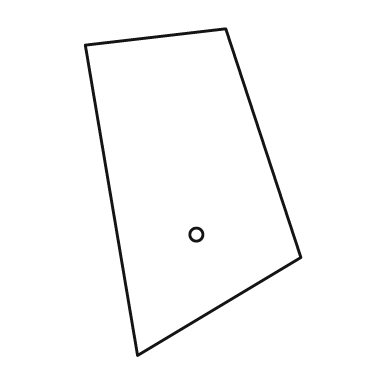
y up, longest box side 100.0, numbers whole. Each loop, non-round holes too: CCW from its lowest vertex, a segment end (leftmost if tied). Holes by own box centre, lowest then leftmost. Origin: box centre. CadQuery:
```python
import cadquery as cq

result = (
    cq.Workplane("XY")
    .moveTo(-17.0, -50.0)
    .lineTo(33.0, -20.0)
    .lineTo(10.0, 50.0)
    .lineTo(-33.0, 45.0)
    .close()
    .moveTo(1.0, -13.0)
    .circle(2.0)
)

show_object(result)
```